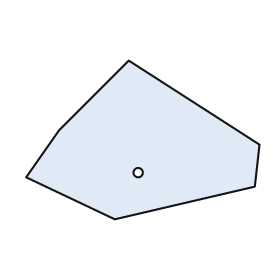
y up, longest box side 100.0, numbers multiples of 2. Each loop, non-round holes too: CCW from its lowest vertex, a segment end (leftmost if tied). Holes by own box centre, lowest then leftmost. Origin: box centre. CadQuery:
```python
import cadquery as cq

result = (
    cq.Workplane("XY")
    .moveTo(-12.0, -34.0)
    .lineTo(48.0, -20.0)
    .lineTo(50.0, -2.0)
    .lineTo(-6.0, 34.0)
    .lineTo(-36.0, 4.0)
    .lineTo(-50.0, -16.0)
    .close()
    .moveTo(-2.0, -14.0)
    .circle(2.0)
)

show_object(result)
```